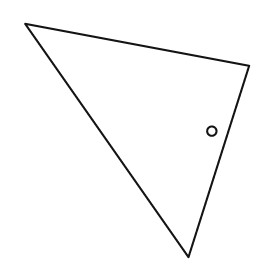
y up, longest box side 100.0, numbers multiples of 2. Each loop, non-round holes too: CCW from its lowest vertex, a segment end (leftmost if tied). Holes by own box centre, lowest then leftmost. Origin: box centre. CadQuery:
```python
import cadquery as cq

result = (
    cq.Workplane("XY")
    .moveTo(22.0, -50.0)
    .lineTo(48.0, 32.0)
    .lineTo(-48.0, 50.0)
    .close()
    .moveTo(32.0, 4.0)
    .circle(2.0)
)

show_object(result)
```